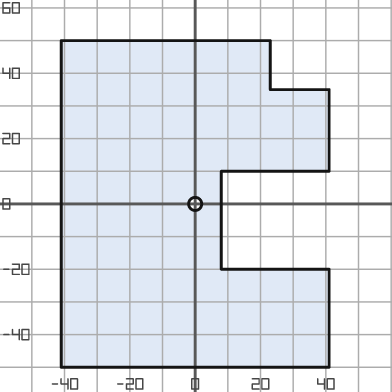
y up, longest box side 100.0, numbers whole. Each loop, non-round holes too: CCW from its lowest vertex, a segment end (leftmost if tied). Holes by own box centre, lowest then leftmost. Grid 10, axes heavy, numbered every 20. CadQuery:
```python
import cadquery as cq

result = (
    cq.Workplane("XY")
    .moveTo(-41.0, -50.0)
    .lineTo(41.0, -50.0)
    .lineTo(41.0, -20.0)
    .lineTo(8.0, -20.0)
    .lineTo(8.0, 10.0)
    .lineTo(41.0, 10.0)
    .lineTo(41.0, 35.0)
    .lineTo(23.0, 35.0)
    .lineTo(23.0, 50.0)
    .lineTo(-41.0, 50.0)
    .close()
    .moveTo(0.0, 0.0)
    .circle(2.0)
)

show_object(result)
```